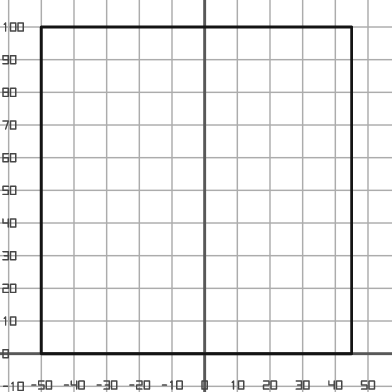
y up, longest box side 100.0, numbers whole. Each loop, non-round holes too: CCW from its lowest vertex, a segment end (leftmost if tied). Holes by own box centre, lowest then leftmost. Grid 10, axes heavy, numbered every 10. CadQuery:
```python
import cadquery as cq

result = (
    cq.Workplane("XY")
    .moveTo(-50.0, 0.0)
    .lineTo(45.0, 0.0)
    .lineTo(45.0, 100.0)
    .lineTo(-50.0, 100.0)
    .close()
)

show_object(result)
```